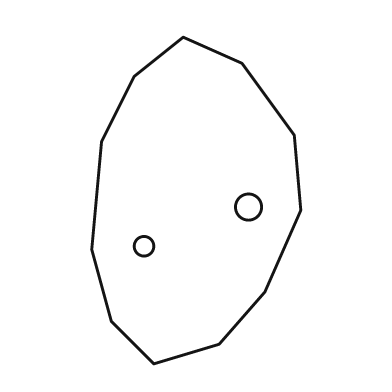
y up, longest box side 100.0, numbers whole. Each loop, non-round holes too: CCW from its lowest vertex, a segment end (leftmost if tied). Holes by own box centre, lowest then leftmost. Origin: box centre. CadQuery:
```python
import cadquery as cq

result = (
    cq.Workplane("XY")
    .moveTo(-13.0, -50.0)
    .lineTo(7.0, -44.0)
    .lineTo(21.0, -28.0)
    .lineTo(32.0, -3.0)
    .lineTo(30.0, 20.0)
    .lineTo(14.0, 42.0)
    .lineTo(-4.0, 50.0)
    .lineTo(-19.0, 38.0)
    .lineTo(-29.0, 18.0)
    .lineTo(-32.0, -15.0)
    .lineTo(-26.0, -37.0)
    .close()
    .moveTo(-16.0, -14.0)
    .circle(3.0)
    .moveTo(16.0, -2.0)
    .circle(4.0)
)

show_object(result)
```